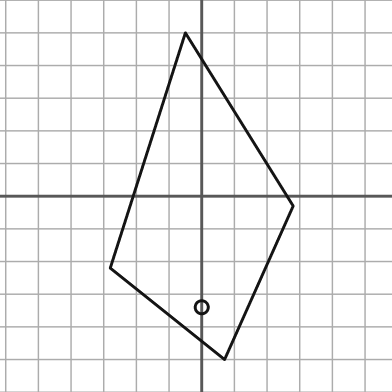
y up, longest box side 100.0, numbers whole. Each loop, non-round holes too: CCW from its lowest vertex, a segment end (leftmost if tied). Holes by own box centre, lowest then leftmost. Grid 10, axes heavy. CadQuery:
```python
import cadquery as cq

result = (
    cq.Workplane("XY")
    .moveTo(7.0, -50.0)
    .lineTo(28.0, -3.0)
    .lineTo(-5.0, 50.0)
    .lineTo(-28.0, -22.0)
    .close()
    .moveTo(0.0, -34.0)
    .circle(2.0)
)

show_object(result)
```